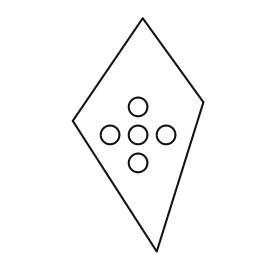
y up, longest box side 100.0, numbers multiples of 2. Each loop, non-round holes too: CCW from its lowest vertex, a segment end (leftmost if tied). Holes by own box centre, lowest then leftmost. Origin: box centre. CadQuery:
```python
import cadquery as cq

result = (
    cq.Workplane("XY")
    .moveTo(8.0, -50.0)
    .lineTo(28.0, 14.0)
    .lineTo(2.0, 50.0)
    .lineTo(-28.0, 6.0)
    .close()
    .moveTo(0.0, -12.0)
    .circle(4.0)
    .moveTo(-12.0, 0.0)
    .circle(4.0)
    .moveTo(0.0, 0.0)
    .circle(4.0)
    .moveTo(12.0, 0.0)
    .circle(4.0)
    .moveTo(0.0, 12.0)
    .circle(4.0)
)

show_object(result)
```